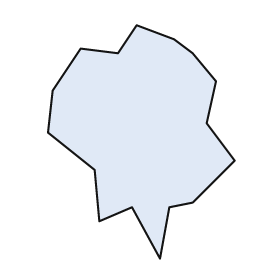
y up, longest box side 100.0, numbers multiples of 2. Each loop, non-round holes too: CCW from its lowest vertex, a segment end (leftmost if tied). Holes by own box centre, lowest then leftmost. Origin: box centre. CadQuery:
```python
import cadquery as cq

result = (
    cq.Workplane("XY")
    .moveTo(8.0, -50.0)
    .lineTo(12.0, -28.0)
    .lineTo(22.0, -26.0)
    .lineTo(40.0, -8.0)
    .lineTo(28.0, 8.0)
    .lineTo(32.0, 26.0)
    .lineTo(22.0, 38.0)
    .lineTo(14.0, 44.0)
    .lineTo(-2.0, 50.0)
    .lineTo(-10.0, 38.0)
    .lineTo(-26.0, 40.0)
    .lineTo(-38.0, 22.0)
    .lineTo(-40.0, 4.0)
    .lineTo(-20.0, -12.0)
    .lineTo(-18.0, -34.0)
    .lineTo(-4.0, -28.0)
    .close()
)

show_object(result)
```